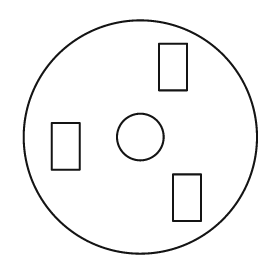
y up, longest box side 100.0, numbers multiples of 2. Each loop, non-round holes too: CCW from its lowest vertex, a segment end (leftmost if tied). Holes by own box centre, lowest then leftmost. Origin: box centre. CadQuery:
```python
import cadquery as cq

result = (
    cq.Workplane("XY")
    .moveTo(0.0, 0.0)
    .circle(50.0)
    .moveTo(14.0, -36.0)
    .lineTo(26.0, -36.0)
    .lineTo(26.0, -16.0)
    .lineTo(14.0, -16.0)
    .close()
    .moveTo(-38.0, -14.0)
    .lineTo(-26.0, -14.0)
    .lineTo(-26.0, 6.0)
    .lineTo(-38.0, 6.0)
    .close()
    .moveTo(0.0, 0.0)
    .circle(10.0)
    .moveTo(8.0, 20.0)
    .lineTo(20.0, 20.0)
    .lineTo(20.0, 40.0)
    .lineTo(8.0, 40.0)
    .close()
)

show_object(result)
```